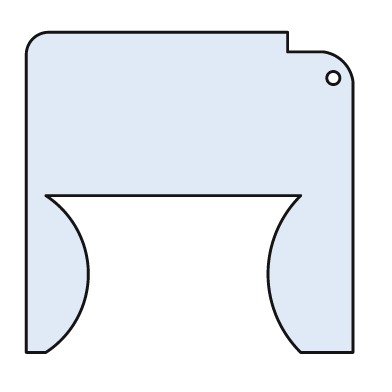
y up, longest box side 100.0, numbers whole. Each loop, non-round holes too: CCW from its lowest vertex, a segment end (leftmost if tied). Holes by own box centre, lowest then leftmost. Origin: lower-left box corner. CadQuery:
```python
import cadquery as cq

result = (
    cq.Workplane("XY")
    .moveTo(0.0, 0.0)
    .lineTo(6.0, 0.0)
    .threePointArc((19.0, 24.0), (6.0, 48.0))
    .lineTo(84.0, 48.0)
    .threePointArc((74.0, 24.0), (84.0, 0.0))
    .lineTo(100.0, 0.0)
    .lineTo(100.0, 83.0)
    .threePointArc((97.0, 89.0), (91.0, 92.0))
    .lineTo(80.0, 92.0)
    .lineTo(80.0, 98.0)
    .lineTo(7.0, 98.0)
    .threePointArc((2.0, 96.0), (0.0, 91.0))
    .close()
    .moveTo(94.0, 84.0)
    .circle(2.0)
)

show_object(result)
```